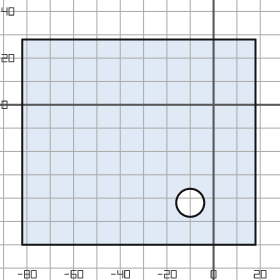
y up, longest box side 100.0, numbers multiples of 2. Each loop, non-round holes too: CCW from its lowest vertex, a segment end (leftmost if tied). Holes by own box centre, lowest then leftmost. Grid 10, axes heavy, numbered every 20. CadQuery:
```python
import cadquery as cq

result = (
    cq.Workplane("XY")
    .moveTo(-82.0, -60.0)
    .lineTo(18.0, -60.0)
    .lineTo(18.0, 28.0)
    .lineTo(-82.0, 28.0)
    .close()
    .moveTo(-10.0, -42.0)
    .circle(6.0)
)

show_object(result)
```